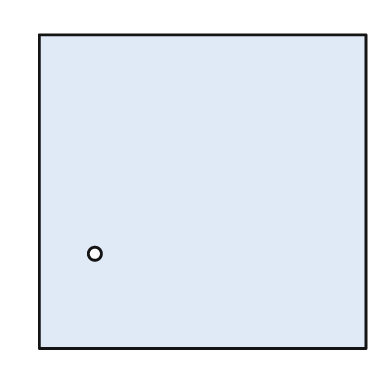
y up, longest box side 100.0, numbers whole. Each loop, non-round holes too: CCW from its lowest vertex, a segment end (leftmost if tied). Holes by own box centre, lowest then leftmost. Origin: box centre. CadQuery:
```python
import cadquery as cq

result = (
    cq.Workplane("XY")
    .moveTo(-50.0, -48.0)
    .lineTo(50.0, -48.0)
    .lineTo(50.0, 48.0)
    .lineTo(-50.0, 48.0)
    .close()
    .moveTo(-33.0, -19.0)
    .circle(2.0)
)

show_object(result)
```